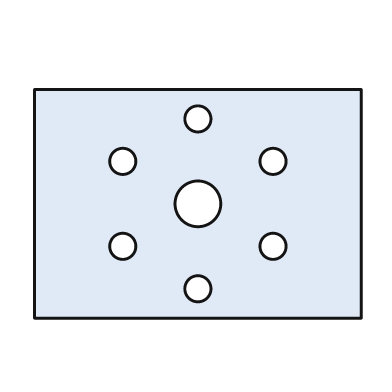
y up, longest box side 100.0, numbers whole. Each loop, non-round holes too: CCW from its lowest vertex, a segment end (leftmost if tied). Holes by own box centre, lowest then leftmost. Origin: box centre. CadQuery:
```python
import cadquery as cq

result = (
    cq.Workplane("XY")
    .moveTo(-50.0, -35.0)
    .lineTo(50.0, -35.0)
    .lineTo(50.0, 35.0)
    .lineTo(-50.0, 35.0)
    .close()
    .moveTo(0.0, -26.0)
    .circle(4.0)
    .moveTo(-23.0, -13.0)
    .circle(4.0)
    .moveTo(23.0, -13.0)
    .circle(4.0)
    .moveTo(0.0, 0.0)
    .circle(7.0)
    .moveTo(-23.0, 13.0)
    .circle(4.0)
    .moveTo(23.0, 13.0)
    .circle(4.0)
    .moveTo(0.0, 26.0)
    .circle(4.0)
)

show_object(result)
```